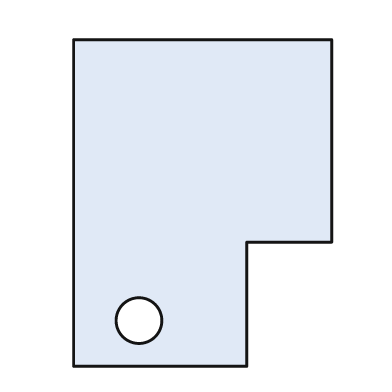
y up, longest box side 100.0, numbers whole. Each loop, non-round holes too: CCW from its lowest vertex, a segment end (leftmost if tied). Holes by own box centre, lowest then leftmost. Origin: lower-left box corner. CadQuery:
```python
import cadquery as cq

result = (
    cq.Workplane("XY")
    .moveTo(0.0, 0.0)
    .lineTo(53.0, 0.0)
    .lineTo(53.0, 38.0)
    .lineTo(79.0, 38.0)
    .lineTo(79.0, 100.0)
    .lineTo(0.0, 100.0)
    .close()
    .moveTo(20.0, 14.0)
    .circle(7.0)
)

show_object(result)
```